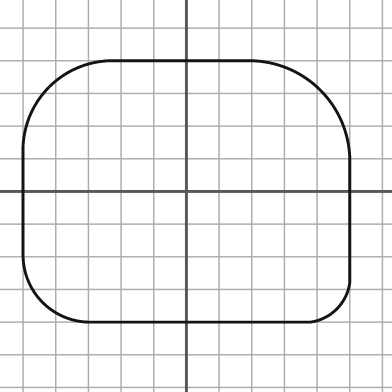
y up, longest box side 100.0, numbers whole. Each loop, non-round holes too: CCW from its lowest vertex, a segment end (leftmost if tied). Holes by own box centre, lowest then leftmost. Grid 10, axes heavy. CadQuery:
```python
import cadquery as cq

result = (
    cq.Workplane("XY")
    .moveTo(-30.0, -40.0)
    .lineTo(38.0, -40.0)
    .threePointArc((46.0, -36.0), (50.0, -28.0))
    .lineTo(50.0, 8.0)
    .threePointArc((41.0, 31.0), (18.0, 40.0))
    .lineTo(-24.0, 40.0)
    .threePointArc((-42.0, 32.0), (-50.0, 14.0))
    .lineTo(-50.0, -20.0)
    .threePointArc((-44.0, -34.0), (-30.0, -40.0))
    .close()
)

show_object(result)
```